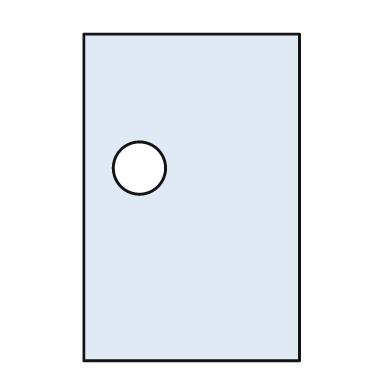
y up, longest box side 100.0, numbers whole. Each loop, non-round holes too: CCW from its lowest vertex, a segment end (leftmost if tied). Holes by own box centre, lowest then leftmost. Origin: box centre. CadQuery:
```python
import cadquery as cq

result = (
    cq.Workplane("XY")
    .moveTo(-33.0, -50.0)
    .lineTo(33.0, -50.0)
    .lineTo(33.0, 50.0)
    .lineTo(-33.0, 50.0)
    .close()
    .moveTo(-16.0, 9.0)
    .circle(8.0)
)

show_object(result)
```